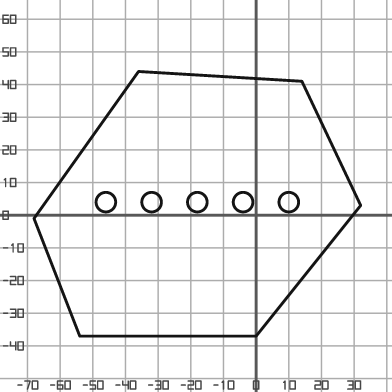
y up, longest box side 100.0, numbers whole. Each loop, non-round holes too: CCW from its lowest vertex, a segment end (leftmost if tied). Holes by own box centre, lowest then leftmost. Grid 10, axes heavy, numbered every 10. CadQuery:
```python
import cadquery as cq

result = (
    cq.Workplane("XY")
    .moveTo(-54.0, -37.0)
    .lineTo(0.0, -37.0)
    .lineTo(32.0, 3.0)
    .lineTo(14.0, 41.0)
    .lineTo(-36.0, 44.0)
    .lineTo(-68.0, -1.0)
    .close()
    .moveTo(-46.0, 4.0)
    .circle(3.0)
    .moveTo(-32.0, 4.0)
    .circle(3.0)
    .moveTo(-18.0, 4.0)
    .circle(3.0)
    .moveTo(-4.0, 4.0)
    .circle(3.0)
    .moveTo(10.0, 4.0)
    .circle(3.0)
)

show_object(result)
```